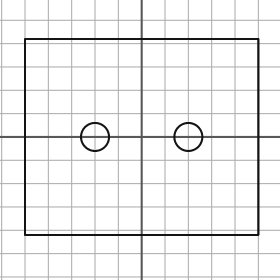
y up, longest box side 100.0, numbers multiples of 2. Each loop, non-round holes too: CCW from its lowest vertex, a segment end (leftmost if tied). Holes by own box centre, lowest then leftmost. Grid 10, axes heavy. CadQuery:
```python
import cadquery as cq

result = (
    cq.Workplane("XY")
    .moveTo(-50.0, -42.0)
    .lineTo(50.0, -42.0)
    .lineTo(50.0, 42.0)
    .lineTo(-50.0, 42.0)
    .close()
    .moveTo(-20.0, 0.0)
    .circle(6.0)
    .moveTo(20.0, 0.0)
    .circle(6.0)
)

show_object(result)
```